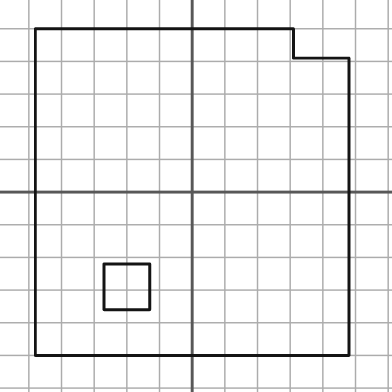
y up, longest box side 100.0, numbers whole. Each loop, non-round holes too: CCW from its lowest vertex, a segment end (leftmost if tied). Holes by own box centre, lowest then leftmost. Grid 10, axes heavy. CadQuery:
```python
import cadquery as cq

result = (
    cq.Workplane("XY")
    .moveTo(-48.0, -50.0)
    .lineTo(48.0, -50.0)
    .lineTo(48.0, 41.0)
    .lineTo(31.0, 41.0)
    .lineTo(31.0, 50.0)
    .lineTo(-48.0, 50.0)
    .close()
    .moveTo(-27.0, -36.0)
    .lineTo(-13.0, -36.0)
    .lineTo(-13.0, -22.0)
    .lineTo(-27.0, -22.0)
    .close()
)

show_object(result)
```